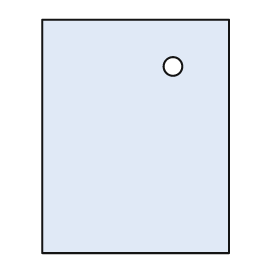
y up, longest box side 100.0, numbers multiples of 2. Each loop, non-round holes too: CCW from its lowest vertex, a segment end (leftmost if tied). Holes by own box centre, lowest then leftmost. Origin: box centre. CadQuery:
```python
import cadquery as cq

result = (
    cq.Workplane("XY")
    .moveTo(-40.0, -50.0)
    .lineTo(40.0, -50.0)
    .lineTo(40.0, 50.0)
    .lineTo(-40.0, 50.0)
    .close()
    .moveTo(16.0, 30.0)
    .circle(4.0)
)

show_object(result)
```